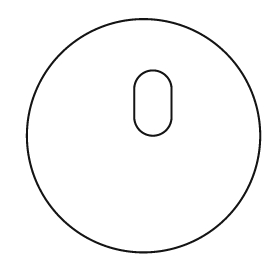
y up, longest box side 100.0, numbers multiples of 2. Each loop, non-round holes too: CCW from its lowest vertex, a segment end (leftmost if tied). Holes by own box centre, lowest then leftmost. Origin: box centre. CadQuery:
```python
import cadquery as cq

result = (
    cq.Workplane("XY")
    .moveTo(0.0, 0.0)
    .circle(50.0)
    .moveTo(-4.0, 8.0)
    .threePointArc((4.0, 0.0), (12.0, 8.0))
    .lineTo(12.0, 20.0)
    .threePointArc((4.0, 28.0), (-4.0, 20.0))
    .close()
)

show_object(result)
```